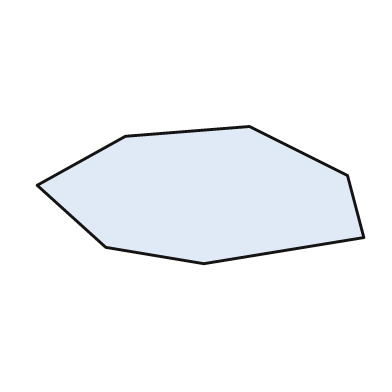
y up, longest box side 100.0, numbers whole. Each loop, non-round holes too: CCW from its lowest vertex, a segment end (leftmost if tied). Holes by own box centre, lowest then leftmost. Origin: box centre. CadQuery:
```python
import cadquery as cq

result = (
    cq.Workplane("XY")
    .moveTo(1.0, -21.0)
    .lineTo(50.0, -13.0)
    .lineTo(45.0, 6.0)
    .lineTo(15.0, 21.0)
    .lineTo(-23.0, 18.0)
    .lineTo(-50.0, 3.0)
    .lineTo(-29.0, -16.0)
    .close()
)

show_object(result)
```